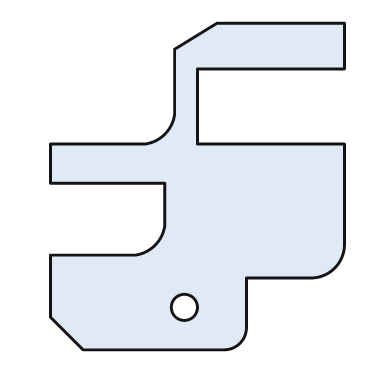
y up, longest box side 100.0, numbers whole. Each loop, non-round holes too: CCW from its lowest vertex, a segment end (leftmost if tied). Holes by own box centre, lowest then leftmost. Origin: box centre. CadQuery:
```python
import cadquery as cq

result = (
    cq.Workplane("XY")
    .moveTo(-35.0, -50.0)
    .lineTo(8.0, -50.0)
    .threePointArc((13.0, -48.0), (15.0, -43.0))
    .lineTo(15.0, -28.0)
    .lineTo(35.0, -28.0)
    .threePointArc((42.0, -25.0), (45.0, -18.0))
    .lineTo(45.0, 13.0)
    .lineTo(0.0, 13.0)
    .lineTo(0.0, 36.0)
    .lineTo(45.0, 36.0)
    .lineTo(45.0, 50.0)
    .lineTo(6.0, 50.0)
    .lineTo(-7.0, 42.0)
    .lineTo(-7.0, 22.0)
    .threePointArc((-10.0, 16.0), (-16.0, 13.0))
    .lineTo(-45.0, 13.0)
    .lineTo(-45.0, 1.0)
    .lineTo(-10.0, 1.0)
    .lineTo(-10.0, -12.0)
    .threePointArc((-13.0, -18.0), (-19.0, -21.0))
    .lineTo(-45.0, -21.0)
    .lineTo(-45.0, -40.0)
    .close()
    .moveTo(-4.0, -37.0)
    .circle(4.0)
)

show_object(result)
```